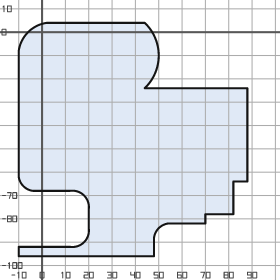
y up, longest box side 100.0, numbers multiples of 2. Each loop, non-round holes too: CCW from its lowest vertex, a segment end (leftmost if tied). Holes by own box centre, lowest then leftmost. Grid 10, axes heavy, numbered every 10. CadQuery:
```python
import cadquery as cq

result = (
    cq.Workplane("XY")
    .moveTo(-10.0, -96.0)
    .lineTo(48.0, -96.0)
    .lineTo(48.0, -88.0)
    .threePointArc((50.0, -84.0), (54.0, -82.0))
    .lineTo(70.0, -82.0)
    .lineTo(70.0, -78.0)
    .lineTo(82.0, -78.0)
    .lineTo(82.0, -64.0)
    .lineTo(88.0, -64.0)
    .lineTo(88.0, -24.0)
    .lineTo(44.0, -24.0)
    .threePointArc((50.0, -10.0), (44.0, 4.0))
    .lineTo(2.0, 4.0)
    .threePointArc((-6.0, 0.0), (-10.0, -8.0))
    .lineTo(-10.0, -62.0)
    .threePointArc((-8.0, -66.0), (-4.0, -68.0))
    .lineTo(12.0, -68.0)
    .threePointArc((18.0, -70.0), (20.0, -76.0))
    .lineTo(20.0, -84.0)
    .threePointArc((18.0, -90.0), (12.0, -92.0))
    .lineTo(-10.0, -92.0)
    .close()
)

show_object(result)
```